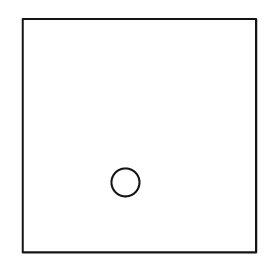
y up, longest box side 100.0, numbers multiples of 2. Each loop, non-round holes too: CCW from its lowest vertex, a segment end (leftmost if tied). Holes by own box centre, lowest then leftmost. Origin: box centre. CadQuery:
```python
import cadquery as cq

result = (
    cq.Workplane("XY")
    .moveTo(-50.0, -50.0)
    .lineTo(50.0, -50.0)
    .lineTo(50.0, 50.0)
    .lineTo(-50.0, 50.0)
    .close()
    .moveTo(-6.0, -20.0)
    .circle(6.0)
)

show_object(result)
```